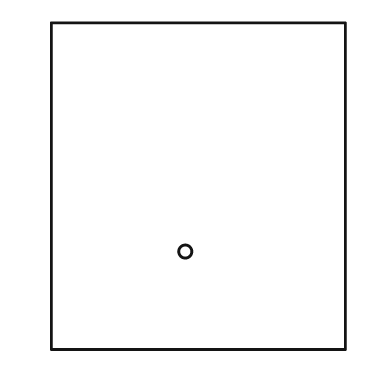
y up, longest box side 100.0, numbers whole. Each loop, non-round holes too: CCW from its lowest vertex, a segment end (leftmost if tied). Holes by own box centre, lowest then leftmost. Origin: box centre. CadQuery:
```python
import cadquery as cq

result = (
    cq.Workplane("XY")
    .moveTo(-45.0, -50.0)
    .lineTo(45.0, -50.0)
    .lineTo(45.0, 50.0)
    .lineTo(-45.0, 50.0)
    .close()
    .moveTo(-4.0, -20.0)
    .circle(2.0)
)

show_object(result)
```